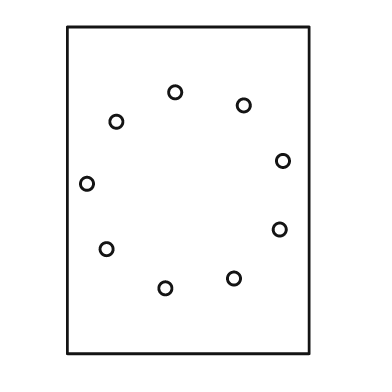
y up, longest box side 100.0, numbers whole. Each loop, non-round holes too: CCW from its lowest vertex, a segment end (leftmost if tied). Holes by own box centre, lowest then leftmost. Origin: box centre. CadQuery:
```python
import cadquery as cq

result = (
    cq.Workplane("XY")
    .moveTo(-37.0, -50.0)
    .lineTo(37.0, -50.0)
    .lineTo(37.0, 50.0)
    .lineTo(-37.0, 50.0)
    .close()
    .moveTo(-7.0, -30.0)
    .circle(2.0)
    .moveTo(14.0, -27.0)
    .circle(2.0)
    .moveTo(-25.0, -18.0)
    .circle(2.0)
    .moveTo(28.0, -12.0)
    .circle(2.0)
    .moveTo(-31.0, 2.0)
    .circle(2.0)
    .moveTo(29.0, 9.0)
    .circle(2.0)
    .moveTo(-22.0, 21.0)
    .circle(2.0)
    .moveTo(17.0, 26.0)
    .circle(2.0)
    .moveTo(-4.0, 30.0)
    .circle(2.0)
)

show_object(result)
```